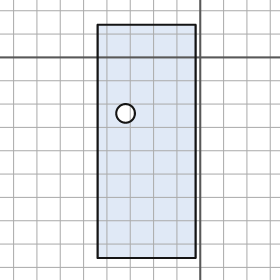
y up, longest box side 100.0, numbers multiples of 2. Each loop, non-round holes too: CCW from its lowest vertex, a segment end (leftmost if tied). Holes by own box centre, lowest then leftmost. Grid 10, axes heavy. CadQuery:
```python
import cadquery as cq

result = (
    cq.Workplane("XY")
    .moveTo(-44.0, -86.0)
    .lineTo(-2.0, -86.0)
    .lineTo(-2.0, 14.0)
    .lineTo(-44.0, 14.0)
    .close()
    .moveTo(-32.0, -24.0)
    .circle(4.0)
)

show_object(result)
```